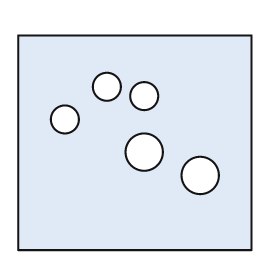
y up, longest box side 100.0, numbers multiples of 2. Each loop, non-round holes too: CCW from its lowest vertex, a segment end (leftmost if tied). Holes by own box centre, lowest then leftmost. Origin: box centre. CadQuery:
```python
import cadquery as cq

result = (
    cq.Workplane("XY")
    .moveTo(-50.0, -46.0)
    .lineTo(50.0, -46.0)
    .lineTo(50.0, 46.0)
    .lineTo(-50.0, 46.0)
    .close()
    .moveTo(28.0, -14.0)
    .circle(8.0)
    .moveTo(4.0, -4.0)
    .circle(8.0)
    .moveTo(-30.0, 10.0)
    .circle(6.0)
    .moveTo(4.0, 20.0)
    .circle(6.0)
    .moveTo(-12.0, 24.0)
    .circle(6.0)
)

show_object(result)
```